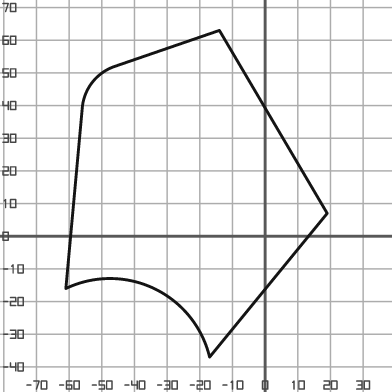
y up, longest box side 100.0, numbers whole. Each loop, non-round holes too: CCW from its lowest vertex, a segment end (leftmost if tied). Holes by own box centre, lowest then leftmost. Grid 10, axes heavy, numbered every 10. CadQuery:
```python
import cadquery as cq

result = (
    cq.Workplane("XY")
    .moveTo(-17.0, -37.0)
    .lineTo(19.0, 7.0)
    .lineTo(-14.0, 63.0)
    .lineTo(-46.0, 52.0)
    .threePointArc((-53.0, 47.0), (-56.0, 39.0))
    .lineTo(-61.0, -16.0)
    .threePointArc((-34.0, -16.0), (-17.0, -37.0))
    .close()
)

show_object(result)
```